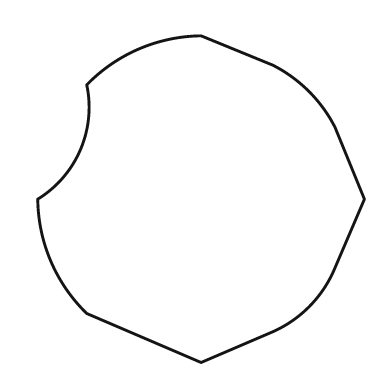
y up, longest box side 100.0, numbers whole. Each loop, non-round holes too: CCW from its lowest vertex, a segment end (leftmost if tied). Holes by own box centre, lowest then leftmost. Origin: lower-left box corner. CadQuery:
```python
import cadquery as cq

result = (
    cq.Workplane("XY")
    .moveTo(50.0, 0.0)
    .lineTo(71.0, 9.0)
    .threePointArc((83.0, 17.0), (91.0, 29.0))
    .lineTo(100.0, 50.0)
    .lineTo(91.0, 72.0)
    .threePointArc((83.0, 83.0), (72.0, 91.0))
    .lineTo(50.0, 100.0)
    .threePointArc((31.0, 96.0), (15.0, 85.0))
    .threePointArc((13.0, 65.0), (0.0, 50.0))
    .threePointArc((4.0, 31.0), (15.0, 15.0))
    .close()
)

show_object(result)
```